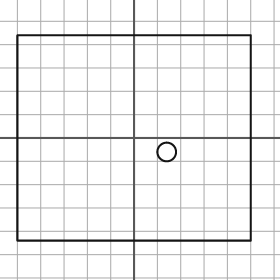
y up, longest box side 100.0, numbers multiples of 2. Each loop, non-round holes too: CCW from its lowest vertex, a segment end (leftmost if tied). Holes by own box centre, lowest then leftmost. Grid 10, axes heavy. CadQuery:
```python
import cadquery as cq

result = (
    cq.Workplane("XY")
    .moveTo(-50.0, -44.0)
    .lineTo(50.0, -44.0)
    .lineTo(50.0, 44.0)
    .lineTo(-50.0, 44.0)
    .close()
    .moveTo(14.0, -6.0)
    .circle(4.0)
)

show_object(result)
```